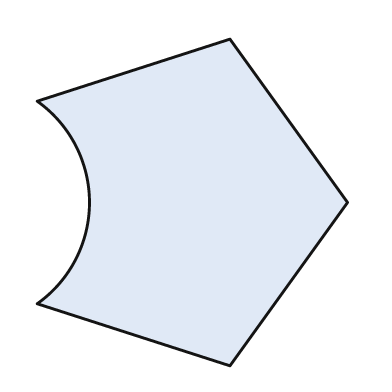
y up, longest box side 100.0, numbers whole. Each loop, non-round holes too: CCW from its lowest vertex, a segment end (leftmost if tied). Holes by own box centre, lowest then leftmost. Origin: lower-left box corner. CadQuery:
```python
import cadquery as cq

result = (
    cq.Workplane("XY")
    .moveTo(59.0, 0.0)
    .lineTo(95.0, 50.0)
    .lineTo(59.0, 100.0)
    .lineTo(0.0, 81.0)
    .threePointArc((16.0, 50.0), (0.0, 19.0))
    .close()
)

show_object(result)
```